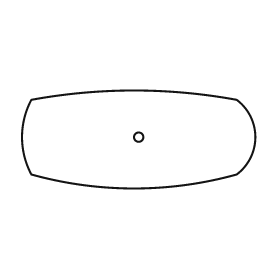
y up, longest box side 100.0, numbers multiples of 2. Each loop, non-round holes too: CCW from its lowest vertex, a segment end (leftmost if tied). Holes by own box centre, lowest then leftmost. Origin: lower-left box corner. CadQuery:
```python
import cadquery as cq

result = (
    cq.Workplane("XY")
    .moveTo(4.0, 6.0)
    .threePointArc((48.0, 0.0), (92.0, 6.0))
    .threePointArc((100.0, 22.0), (92.0, 38.0))
    .threePointArc((48.0, 42.0), (4.0, 38.0))
    .threePointArc((0.0, 22.0), (4.0, 6.0))
    .close()
    .moveTo(50.0, 22.0)
    .circle(2.0)
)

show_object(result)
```